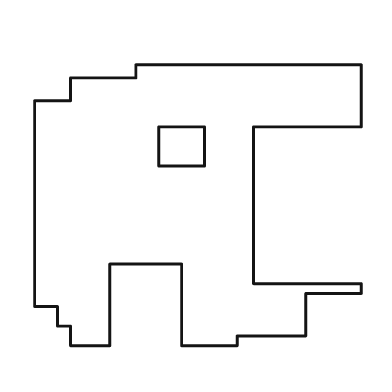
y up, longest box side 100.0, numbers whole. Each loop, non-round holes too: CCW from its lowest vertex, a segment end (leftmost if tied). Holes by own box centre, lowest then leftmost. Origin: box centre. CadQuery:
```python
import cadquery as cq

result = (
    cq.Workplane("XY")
    .moveTo(-39.0, -43.0)
    .lineTo(-27.0, -43.0)
    .lineTo(-27.0, -18.0)
    .lineTo(-5.0, -18.0)
    .lineTo(-5.0, -43.0)
    .lineTo(12.0, -43.0)
    .lineTo(12.0, -40.0)
    .lineTo(33.0, -40.0)
    .lineTo(33.0, -27.0)
    .lineTo(50.0, -27.0)
    .lineTo(50.0, -24.0)
    .lineTo(17.0, -24.0)
    .lineTo(17.0, 24.0)
    .lineTo(50.0, 24.0)
    .lineTo(50.0, 43.0)
    .lineTo(-19.0, 43.0)
    .lineTo(-19.0, 39.0)
    .lineTo(-39.0, 39.0)
    .lineTo(-39.0, 32.0)
    .lineTo(-50.0, 32.0)
    .lineTo(-50.0, -31.0)
    .lineTo(-43.0, -31.0)
    .lineTo(-43.0, -37.0)
    .lineTo(-39.0, -37.0)
    .close()
    .moveTo(-12.0, 12.0)
    .lineTo(2.0, 12.0)
    .lineTo(2.0, 24.0)
    .lineTo(-12.0, 24.0)
    .close()
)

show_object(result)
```